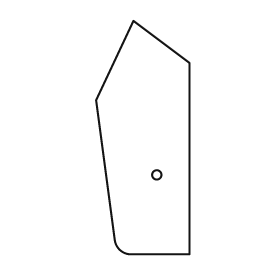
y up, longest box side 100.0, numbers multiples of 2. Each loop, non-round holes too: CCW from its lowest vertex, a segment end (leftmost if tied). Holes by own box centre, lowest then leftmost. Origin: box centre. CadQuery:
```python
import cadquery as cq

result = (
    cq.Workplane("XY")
    .moveTo(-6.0, -50.0)
    .lineTo(20.0, -50.0)
    .lineTo(20.0, 32.0)
    .lineTo(-4.0, 50.0)
    .lineTo(-20.0, 16.0)
    .lineTo(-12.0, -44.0)
    .threePointArc((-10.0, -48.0), (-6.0, -50.0))
    .close()
    .moveTo(6.0, -16.0)
    .circle(2.0)
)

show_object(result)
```